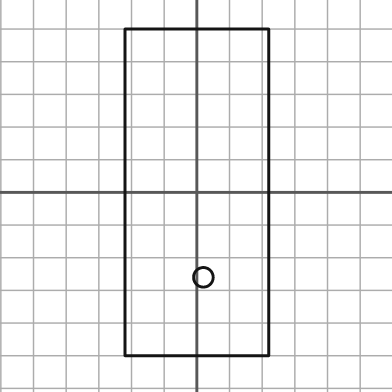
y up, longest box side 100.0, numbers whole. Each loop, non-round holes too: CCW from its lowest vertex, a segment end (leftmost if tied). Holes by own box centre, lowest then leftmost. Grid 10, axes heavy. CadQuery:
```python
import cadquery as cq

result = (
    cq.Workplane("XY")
    .moveTo(-22.0, -50.0)
    .lineTo(22.0, -50.0)
    .lineTo(22.0, 50.0)
    .lineTo(-22.0, 50.0)
    .close()
    .moveTo(2.0, -26.0)
    .circle(3.0)
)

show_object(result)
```